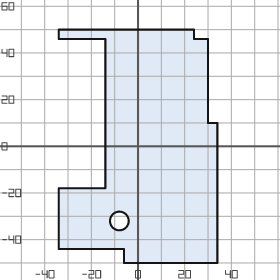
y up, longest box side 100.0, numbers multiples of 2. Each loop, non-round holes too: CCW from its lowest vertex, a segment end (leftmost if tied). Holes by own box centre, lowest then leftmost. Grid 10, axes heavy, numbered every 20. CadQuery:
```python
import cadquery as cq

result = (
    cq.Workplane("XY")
    .moveTo(-6.0, -50.0)
    .lineTo(34.0, -50.0)
    .lineTo(34.0, 10.0)
    .lineTo(30.0, 10.0)
    .lineTo(30.0, 46.0)
    .lineTo(24.0, 46.0)
    .lineTo(24.0, 50.0)
    .lineTo(-34.0, 50.0)
    .lineTo(-34.0, 46.0)
    .lineTo(-14.0, 46.0)
    .lineTo(-14.0, -18.0)
    .lineTo(-34.0, -18.0)
    .lineTo(-34.0, -44.0)
    .lineTo(-6.0, -44.0)
    .close()
    .moveTo(-8.0, -32.0)
    .circle(4.0)
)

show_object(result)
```